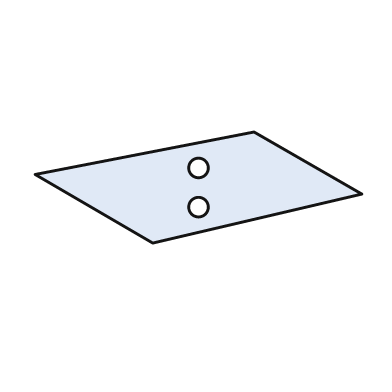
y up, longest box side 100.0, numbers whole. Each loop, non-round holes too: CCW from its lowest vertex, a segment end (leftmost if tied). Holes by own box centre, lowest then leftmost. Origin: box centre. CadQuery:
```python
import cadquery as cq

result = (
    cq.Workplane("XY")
    .moveTo(-14.0, -17.0)
    .lineTo(50.0, -2.0)
    .lineTo(17.0, 17.0)
    .lineTo(-50.0, 4.0)
    .close()
    .moveTo(0.0, -6.0)
    .circle(3.0)
    .moveTo(0.0, 6.0)
    .circle(3.0)
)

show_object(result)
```